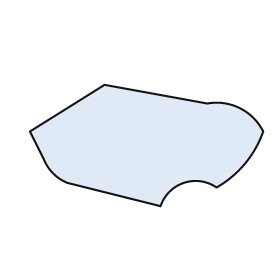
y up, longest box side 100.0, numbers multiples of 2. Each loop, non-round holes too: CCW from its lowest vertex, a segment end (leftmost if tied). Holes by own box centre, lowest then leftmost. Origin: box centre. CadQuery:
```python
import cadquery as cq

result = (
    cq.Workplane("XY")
    .moveTo(6.0, -26.0)
    .threePointArc((16.0, -16.0), (30.0, -18.0))
    .threePointArc((42.0, -8.0), (50.0, 6.0))
    .threePointArc((40.0, 16.0), (26.0, 18.0))
    .lineTo(-18.0, 26.0)
    .lineTo(-50.0, 6.0)
    .lineTo(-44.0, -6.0)
    .threePointArc((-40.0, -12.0), (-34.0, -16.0))
    .close()
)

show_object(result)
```